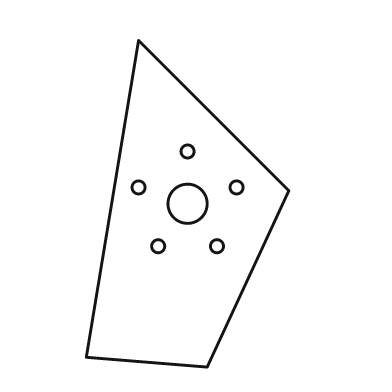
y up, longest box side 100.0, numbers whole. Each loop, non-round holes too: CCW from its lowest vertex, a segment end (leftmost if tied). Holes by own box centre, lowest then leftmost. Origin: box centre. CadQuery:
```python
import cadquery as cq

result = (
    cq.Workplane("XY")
    .moveTo(6.0, -50.0)
    .lineTo(31.0, 4.0)
    .lineTo(-15.0, 50.0)
    .lineTo(-31.0, -47.0)
    .close()
    .moveTo(-9.0, -13.0)
    .circle(2.0)
    .moveTo(9.0, -13.0)
    .circle(2.0)
    .moveTo(0.0, 0.0)
    .circle(6.0)
    .moveTo(-15.0, 5.0)
    .circle(2.0)
    .moveTo(15.0, 5.0)
    .circle(2.0)
    .moveTo(0.0, 16.0)
    .circle(2.0)
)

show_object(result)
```